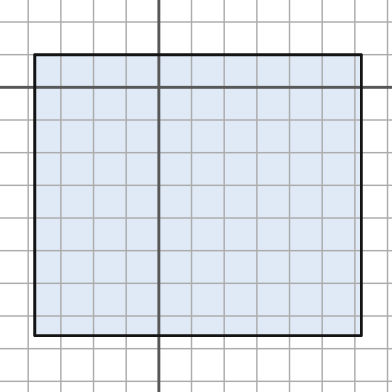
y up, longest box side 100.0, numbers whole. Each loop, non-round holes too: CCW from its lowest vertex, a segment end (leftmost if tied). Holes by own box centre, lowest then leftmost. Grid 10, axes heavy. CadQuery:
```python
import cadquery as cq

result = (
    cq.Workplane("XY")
    .moveTo(-38.0, -76.0)
    .lineTo(62.0, -76.0)
    .lineTo(62.0, 10.0)
    .lineTo(-38.0, 10.0)
    .close()
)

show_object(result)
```